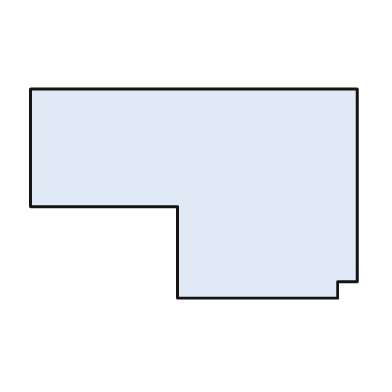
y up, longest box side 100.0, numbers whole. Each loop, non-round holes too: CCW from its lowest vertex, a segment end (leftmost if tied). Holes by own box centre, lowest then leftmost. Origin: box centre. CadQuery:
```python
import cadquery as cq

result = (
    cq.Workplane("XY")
    .moveTo(-5.0, -32.0)
    .lineTo(44.0, -32.0)
    .lineTo(44.0, -27.0)
    .lineTo(50.0, -27.0)
    .lineTo(50.0, 32.0)
    .lineTo(-50.0, 32.0)
    .lineTo(-50.0, -4.0)
    .lineTo(-5.0, -4.0)
    .close()
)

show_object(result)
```